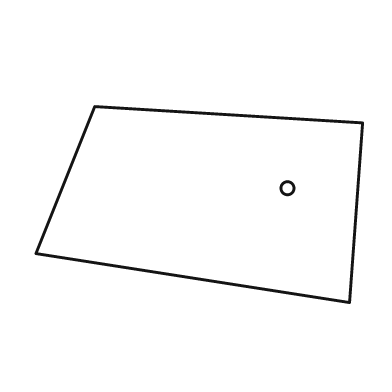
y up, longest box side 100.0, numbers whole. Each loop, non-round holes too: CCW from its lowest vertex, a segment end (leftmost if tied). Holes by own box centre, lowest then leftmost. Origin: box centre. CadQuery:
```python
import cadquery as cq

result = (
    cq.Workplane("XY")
    .moveTo(46.0, -30.0)
    .lineTo(50.0, 25.0)
    .lineTo(-32.0, 30.0)
    .lineTo(-50.0, -15.0)
    .close()
    .moveTo(27.0, 5.0)
    .circle(2.0)
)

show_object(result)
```